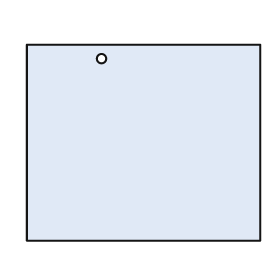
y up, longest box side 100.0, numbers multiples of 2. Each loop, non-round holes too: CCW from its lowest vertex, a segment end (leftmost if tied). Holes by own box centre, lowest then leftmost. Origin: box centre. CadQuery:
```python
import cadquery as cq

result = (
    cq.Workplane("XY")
    .moveTo(-50.0, -42.0)
    .lineTo(50.0, -42.0)
    .lineTo(50.0, 42.0)
    .lineTo(-50.0, 42.0)
    .close()
    .moveTo(-18.0, 36.0)
    .circle(2.0)
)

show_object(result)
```